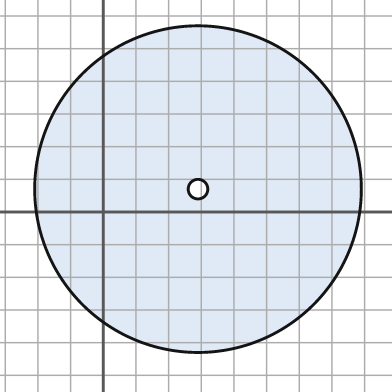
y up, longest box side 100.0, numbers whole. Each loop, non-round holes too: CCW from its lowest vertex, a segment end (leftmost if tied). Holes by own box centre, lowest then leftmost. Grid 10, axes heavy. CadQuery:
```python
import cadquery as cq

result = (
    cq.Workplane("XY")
    .moveTo(29.0, 7.0)
    .circle(50.0)
    .moveTo(29.0, 7.0)
    .circle(3.0)
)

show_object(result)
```